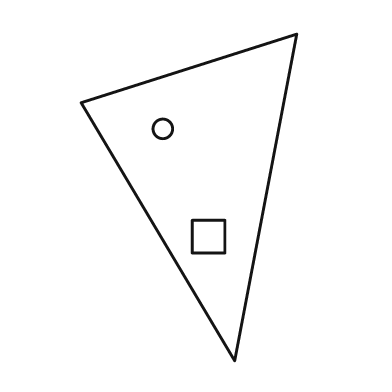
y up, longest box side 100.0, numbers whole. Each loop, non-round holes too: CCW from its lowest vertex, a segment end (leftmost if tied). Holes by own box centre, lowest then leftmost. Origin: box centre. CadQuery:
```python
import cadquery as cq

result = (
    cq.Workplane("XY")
    .moveTo(14.0, -50.0)
    .lineTo(33.0, 50.0)
    .lineTo(-33.0, 29.0)
    .close()
    .moveTo(1.0, -17.0)
    .lineTo(11.0, -17.0)
    .lineTo(11.0, -7.0)
    .lineTo(1.0, -7.0)
    .close()
    .moveTo(-8.0, 21.0)
    .circle(3.0)
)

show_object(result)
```